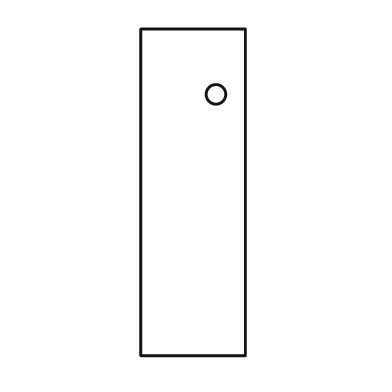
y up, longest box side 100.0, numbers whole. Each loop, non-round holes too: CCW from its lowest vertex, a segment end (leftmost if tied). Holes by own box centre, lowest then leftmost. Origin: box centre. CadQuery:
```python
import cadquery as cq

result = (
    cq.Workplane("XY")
    .moveTo(-16.0, -50.0)
    .lineTo(16.0, -50.0)
    .lineTo(16.0, 50.0)
    .lineTo(-16.0, 50.0)
    .close()
    .moveTo(7.0, 30.0)
    .circle(3.0)
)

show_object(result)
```